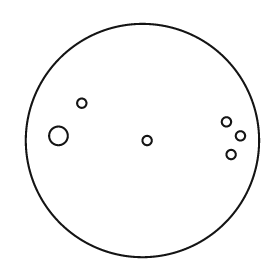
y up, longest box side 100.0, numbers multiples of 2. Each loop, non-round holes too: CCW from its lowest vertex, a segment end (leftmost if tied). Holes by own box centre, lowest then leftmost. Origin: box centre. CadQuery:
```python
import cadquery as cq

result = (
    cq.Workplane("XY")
    .moveTo(0.0, 0.0)
    .circle(50.0)
    .moveTo(38.0, -6.0)
    .circle(2.0)
    .moveTo(2.0, 0.0)
    .circle(2.0)
    .moveTo(-36.0, 2.0)
    .circle(4.0)
    .moveTo(42.0, 2.0)
    .circle(2.0)
    .moveTo(36.0, 8.0)
    .circle(2.0)
    .moveTo(-26.0, 16.0)
    .circle(2.0)
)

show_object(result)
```